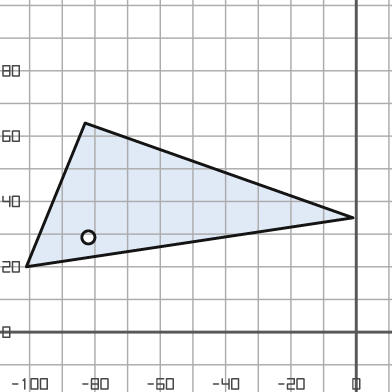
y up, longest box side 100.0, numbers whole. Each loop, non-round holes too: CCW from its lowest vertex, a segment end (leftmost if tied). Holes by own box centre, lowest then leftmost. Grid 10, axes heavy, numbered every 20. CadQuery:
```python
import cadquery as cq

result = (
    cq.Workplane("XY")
    .moveTo(-101.0, 20.0)
    .lineTo(-1.0, 35.0)
    .lineTo(-83.0, 64.0)
    .close()
    .moveTo(-82.0, 29.0)
    .circle(2.0)
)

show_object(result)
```